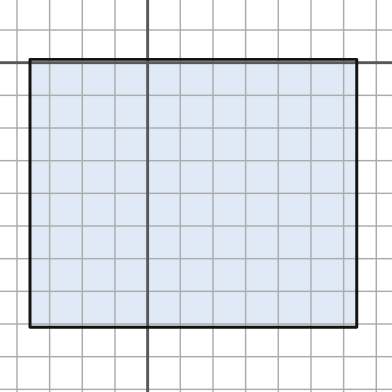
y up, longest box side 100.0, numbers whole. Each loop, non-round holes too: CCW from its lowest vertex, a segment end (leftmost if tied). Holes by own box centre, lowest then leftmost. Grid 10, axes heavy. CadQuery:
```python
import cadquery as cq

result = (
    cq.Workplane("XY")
    .moveTo(-36.0, -81.0)
    .lineTo(64.0, -81.0)
    .lineTo(64.0, 1.0)
    .lineTo(-36.0, 1.0)
    .close()
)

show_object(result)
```